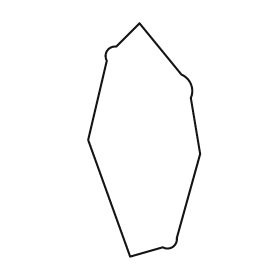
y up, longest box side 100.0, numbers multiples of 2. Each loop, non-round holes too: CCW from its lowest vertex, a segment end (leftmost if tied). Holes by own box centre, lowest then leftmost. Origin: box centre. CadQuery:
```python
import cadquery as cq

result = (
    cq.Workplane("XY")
    .moveTo(-6.0, -50.0)
    .lineTo(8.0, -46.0)
    .threePointArc((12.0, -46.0), (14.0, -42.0))
    .lineTo(24.0, -6.0)
    .lineTo(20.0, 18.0)
    .threePointArc((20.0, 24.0), (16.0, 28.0))
    .lineTo(-2.0, 50.0)
    .lineTo(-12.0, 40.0)
    .threePointArc((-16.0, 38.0), (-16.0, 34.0))
    .lineTo(-24.0, 0.0)
    .close()
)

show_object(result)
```